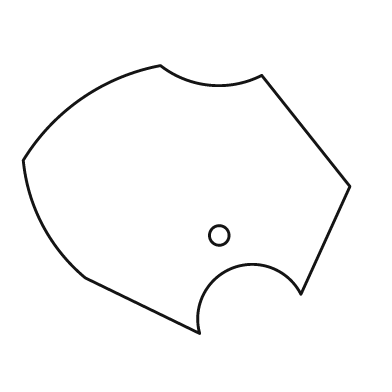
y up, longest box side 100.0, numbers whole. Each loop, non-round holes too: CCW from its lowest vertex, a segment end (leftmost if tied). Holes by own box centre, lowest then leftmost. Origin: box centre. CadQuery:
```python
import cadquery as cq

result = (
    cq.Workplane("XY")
    .moveTo(4.0, -41.0)
    .threePointArc((14.0, -21.0), (35.0, -29.0))
    .lineTo(50.0, 4.0)
    .lineTo(23.0, 38.0)
    .threePointArc((7.0, 35.0), (-8.0, 41.0))
    .threePointArc((-32.0, 31.0), (-50.0, 12.0))
    .threePointArc((-44.0, -8.0), (-31.0, -24.0))
    .close()
    .moveTo(10.0, -11.0)
    .circle(3.0)
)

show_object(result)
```